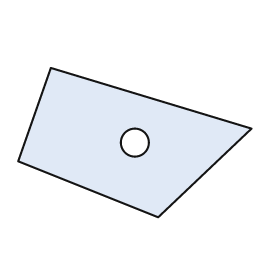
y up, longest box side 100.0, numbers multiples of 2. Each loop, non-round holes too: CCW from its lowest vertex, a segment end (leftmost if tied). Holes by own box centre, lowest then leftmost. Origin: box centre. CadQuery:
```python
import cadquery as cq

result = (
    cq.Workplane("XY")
    .moveTo(10.0, -32.0)
    .lineTo(50.0, 6.0)
    .lineTo(-36.0, 32.0)
    .lineTo(-50.0, -8.0)
    .close()
    .moveTo(0.0, 0.0)
    .circle(6.0)
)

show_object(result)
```